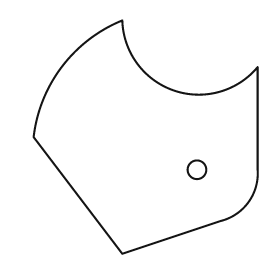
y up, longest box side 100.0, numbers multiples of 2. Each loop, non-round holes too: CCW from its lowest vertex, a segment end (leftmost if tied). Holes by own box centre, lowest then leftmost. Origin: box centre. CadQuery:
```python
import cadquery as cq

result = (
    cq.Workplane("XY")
    .moveTo(-10.0, -50.0)
    .lineTo(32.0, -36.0)
    .threePointArc((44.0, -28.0), (48.0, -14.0))
    .lineTo(48.0, 30.0)
    .threePointArc((12.0, 20.0), (-10.0, 50.0))
    .threePointArc((-36.0, 30.0), (-48.0, 0.0))
    .close()
    .moveTo(22.0, -14.0)
    .circle(4.0)
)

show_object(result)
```